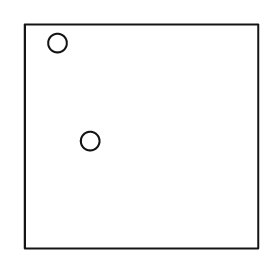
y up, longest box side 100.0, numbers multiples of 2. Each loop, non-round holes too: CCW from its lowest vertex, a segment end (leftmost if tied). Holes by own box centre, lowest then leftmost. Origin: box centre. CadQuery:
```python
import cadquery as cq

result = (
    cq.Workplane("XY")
    .moveTo(-50.0, -48.0)
    .lineTo(50.0, -48.0)
    .lineTo(50.0, 48.0)
    .lineTo(-50.0, 48.0)
    .close()
    .moveTo(-22.0, -2.0)
    .circle(4.0)
    .moveTo(-36.0, 40.0)
    .circle(4.0)
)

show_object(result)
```